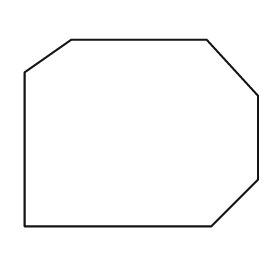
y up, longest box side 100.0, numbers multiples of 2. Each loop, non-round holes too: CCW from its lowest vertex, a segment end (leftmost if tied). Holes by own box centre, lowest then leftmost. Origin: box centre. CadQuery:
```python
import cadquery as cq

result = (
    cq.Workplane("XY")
    .moveTo(-50.0, -40.0)
    .lineTo(30.0, -40.0)
    .lineTo(50.0, -20.0)
    .lineTo(50.0, 16.0)
    .lineTo(28.0, 40.0)
    .lineTo(-30.0, 40.0)
    .lineTo(-50.0, 26.0)
    .close()
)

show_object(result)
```